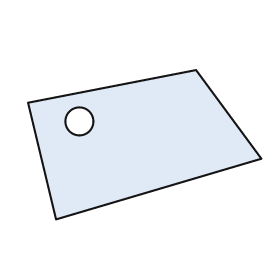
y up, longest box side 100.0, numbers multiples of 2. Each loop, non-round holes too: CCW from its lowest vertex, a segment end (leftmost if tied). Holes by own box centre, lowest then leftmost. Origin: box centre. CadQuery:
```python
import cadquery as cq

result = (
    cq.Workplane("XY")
    .moveTo(-38.0, -32.0)
    .lineTo(50.0, -6.0)
    .lineTo(22.0, 32.0)
    .lineTo(-50.0, 18.0)
    .close()
    .moveTo(-28.0, 10.0)
    .circle(6.0)
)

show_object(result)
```